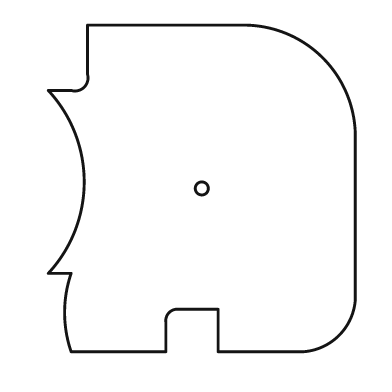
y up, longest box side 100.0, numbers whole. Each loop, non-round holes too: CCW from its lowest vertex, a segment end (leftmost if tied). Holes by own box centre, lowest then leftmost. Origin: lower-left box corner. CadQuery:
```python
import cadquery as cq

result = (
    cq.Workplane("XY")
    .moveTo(7.0, 0.0)
    .lineTo(36.0, 0.0)
    .lineTo(36.0, 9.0)
    .threePointArc((37.0, 12.0), (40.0, 13.0))
    .lineTo(52.0, 13.0)
    .lineTo(52.0, 0.0)
    .lineTo(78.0, 0.0)
    .threePointArc((89.0, 5.0), (94.0, 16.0))
    .lineTo(94.0, 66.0)
    .threePointArc((84.0, 90.0), (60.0, 100.0))
    .lineTo(12.0, 100.0)
    .lineTo(12.0, 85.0)
    .threePointArc((11.0, 81.0), (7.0, 80.0))
    .lineTo(0.0, 80.0)
    .threePointArc((11.0, 52.0), (0.0, 24.0))
    .lineTo(7.0, 24.0)
    .threePointArc((5.0, 12.0), (7.0, 0.0))
    .close()
    .moveTo(47.0, 50.0)
    .circle(2.0)
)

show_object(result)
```